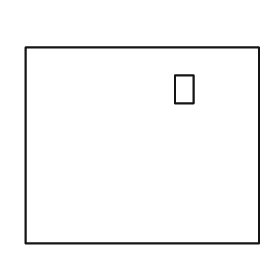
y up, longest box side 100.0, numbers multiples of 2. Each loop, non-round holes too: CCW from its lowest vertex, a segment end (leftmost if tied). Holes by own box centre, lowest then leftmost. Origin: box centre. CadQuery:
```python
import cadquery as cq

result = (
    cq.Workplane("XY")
    .moveTo(-50.0, -42.0)
    .lineTo(50.0, -42.0)
    .lineTo(50.0, 42.0)
    .lineTo(-50.0, 42.0)
    .close()
    .moveTo(14.0, 18.0)
    .lineTo(22.0, 18.0)
    .lineTo(22.0, 30.0)
    .lineTo(14.0, 30.0)
    .close()
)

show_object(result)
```